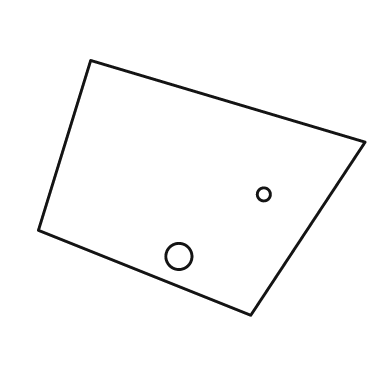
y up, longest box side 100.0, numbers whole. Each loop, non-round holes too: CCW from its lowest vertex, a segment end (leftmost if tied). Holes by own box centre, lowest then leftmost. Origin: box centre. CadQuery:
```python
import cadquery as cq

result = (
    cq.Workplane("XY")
    .moveTo(15.0, -39.0)
    .lineTo(50.0, 14.0)
    .lineTo(-34.0, 39.0)
    .lineTo(-50.0, -13.0)
    .close()
    .moveTo(-7.0, -21.0)
    .circle(4.0)
    .moveTo(19.0, -2.0)
    .circle(2.0)
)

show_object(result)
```